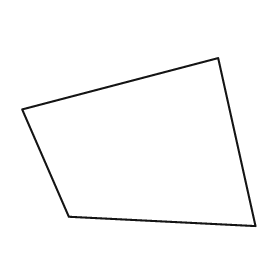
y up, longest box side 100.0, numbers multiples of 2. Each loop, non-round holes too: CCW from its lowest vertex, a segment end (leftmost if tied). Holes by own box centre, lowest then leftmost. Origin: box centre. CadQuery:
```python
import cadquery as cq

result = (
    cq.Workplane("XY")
    .moveTo(50.0, -36.0)
    .lineTo(34.0, 36.0)
    .lineTo(-50.0, 14.0)
    .lineTo(-30.0, -32.0)
    .close()
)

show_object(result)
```